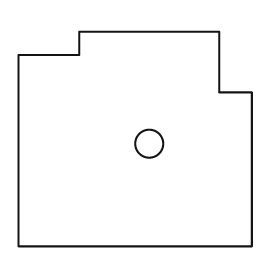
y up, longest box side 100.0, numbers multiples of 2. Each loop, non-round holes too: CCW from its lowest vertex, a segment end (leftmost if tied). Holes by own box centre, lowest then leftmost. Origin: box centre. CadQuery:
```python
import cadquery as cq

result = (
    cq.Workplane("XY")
    .moveTo(-50.0, -46.0)
    .lineTo(50.0, -46.0)
    .lineTo(50.0, 20.0)
    .lineTo(36.0, 20.0)
    .lineTo(36.0, 46.0)
    .lineTo(-24.0, 46.0)
    .lineTo(-24.0, 36.0)
    .lineTo(-50.0, 36.0)
    .close()
    .moveTo(6.0, -2.0)
    .circle(6.0)
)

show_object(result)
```